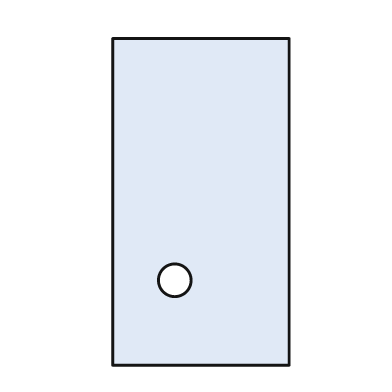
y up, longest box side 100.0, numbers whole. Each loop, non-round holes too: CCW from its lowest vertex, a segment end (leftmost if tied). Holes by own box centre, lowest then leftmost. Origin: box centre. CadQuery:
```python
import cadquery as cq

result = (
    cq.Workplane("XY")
    .moveTo(-27.0, -50.0)
    .lineTo(27.0, -50.0)
    .lineTo(27.0, 50.0)
    .lineTo(-27.0, 50.0)
    .close()
    .moveTo(-8.0, -24.0)
    .circle(5.0)
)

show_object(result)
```